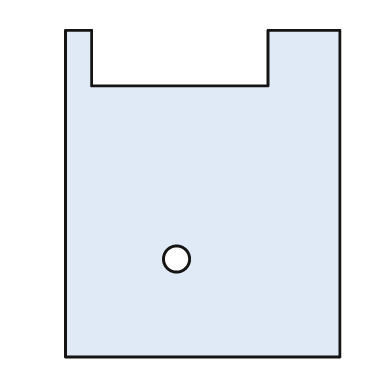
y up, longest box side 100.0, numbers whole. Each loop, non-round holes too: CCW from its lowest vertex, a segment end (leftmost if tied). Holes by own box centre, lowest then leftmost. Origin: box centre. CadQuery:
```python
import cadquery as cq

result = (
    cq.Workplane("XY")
    .moveTo(-42.0, -50.0)
    .lineTo(42.0, -50.0)
    .lineTo(42.0, 50.0)
    .lineTo(20.0, 50.0)
    .lineTo(20.0, 33.0)
    .lineTo(-34.0, 33.0)
    .lineTo(-34.0, 50.0)
    .lineTo(-42.0, 50.0)
    .close()
    .moveTo(-8.0, -20.0)
    .circle(4.0)
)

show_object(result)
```